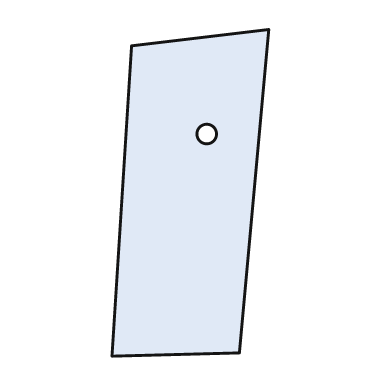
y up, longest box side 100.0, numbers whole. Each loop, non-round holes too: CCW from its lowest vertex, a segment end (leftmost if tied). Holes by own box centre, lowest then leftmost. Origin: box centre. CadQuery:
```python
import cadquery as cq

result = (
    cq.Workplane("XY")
    .moveTo(-24.0, -50.0)
    .lineTo(15.0, -49.0)
    .lineTo(24.0, 50.0)
    .lineTo(-18.0, 45.0)
    .close()
    .moveTo(5.0, 18.0)
    .circle(3.0)
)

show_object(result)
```